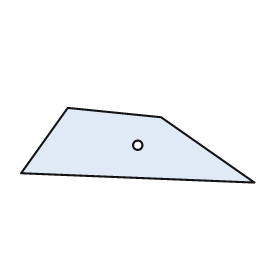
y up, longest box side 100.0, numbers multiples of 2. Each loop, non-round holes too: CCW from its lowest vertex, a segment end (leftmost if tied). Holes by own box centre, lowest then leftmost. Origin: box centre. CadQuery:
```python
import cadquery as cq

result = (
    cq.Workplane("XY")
    .moveTo(50.0, -16.0)
    .lineTo(10.0, 12.0)
    .lineTo(-30.0, 16.0)
    .lineTo(-50.0, -12.0)
    .close()
    .moveTo(0.0, 0.0)
    .circle(2.0)
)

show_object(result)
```